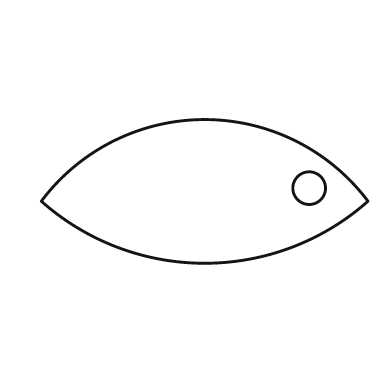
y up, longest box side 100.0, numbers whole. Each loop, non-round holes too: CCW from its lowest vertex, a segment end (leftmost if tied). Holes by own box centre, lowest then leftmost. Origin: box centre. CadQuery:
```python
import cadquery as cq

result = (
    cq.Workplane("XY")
    .moveTo(-50.0, -3.0)
    .threePointArc((0.0, -22.0), (50.0, -3.0))
    .threePointArc((0.0, 22.0), (-50.0, -3.0))
    .close()
    .moveTo(32.0, 1.0)
    .circle(5.0)
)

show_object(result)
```